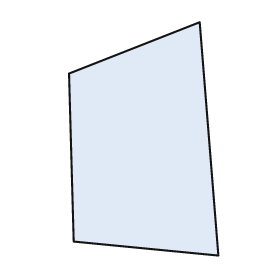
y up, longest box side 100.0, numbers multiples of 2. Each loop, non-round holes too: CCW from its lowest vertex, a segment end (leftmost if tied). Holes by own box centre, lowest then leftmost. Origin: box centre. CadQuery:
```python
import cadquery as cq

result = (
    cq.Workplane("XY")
    .moveTo(32.0, -50.0)
    .lineTo(24.0, 50.0)
    .lineTo(-32.0, 28.0)
    .lineTo(-30.0, -44.0)
    .close()
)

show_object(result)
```